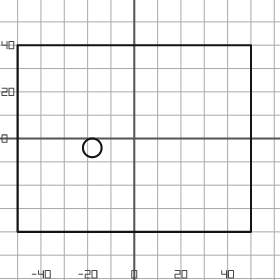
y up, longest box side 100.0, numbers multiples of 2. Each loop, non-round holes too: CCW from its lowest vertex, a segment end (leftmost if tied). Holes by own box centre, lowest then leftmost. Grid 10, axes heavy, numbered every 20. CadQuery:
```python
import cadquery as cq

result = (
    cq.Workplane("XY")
    .moveTo(-50.0, -40.0)
    .lineTo(50.0, -40.0)
    .lineTo(50.0, 40.0)
    .lineTo(-50.0, 40.0)
    .close()
    .moveTo(-18.0, -4.0)
    .circle(4.0)
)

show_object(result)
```